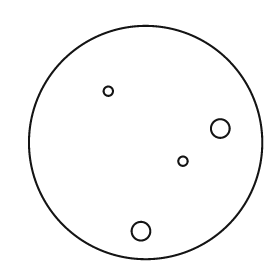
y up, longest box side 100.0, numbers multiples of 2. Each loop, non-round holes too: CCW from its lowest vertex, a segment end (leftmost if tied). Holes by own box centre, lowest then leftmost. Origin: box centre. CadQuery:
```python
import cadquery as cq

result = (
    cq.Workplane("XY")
    .moveTo(0.0, 0.0)
    .circle(50.0)
    .moveTo(-2.0, -38.0)
    .circle(4.0)
    .moveTo(16.0, -8.0)
    .circle(2.0)
    .moveTo(32.0, 6.0)
    .circle(4.0)
    .moveTo(-16.0, 22.0)
    .circle(2.0)
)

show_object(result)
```